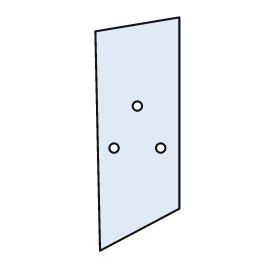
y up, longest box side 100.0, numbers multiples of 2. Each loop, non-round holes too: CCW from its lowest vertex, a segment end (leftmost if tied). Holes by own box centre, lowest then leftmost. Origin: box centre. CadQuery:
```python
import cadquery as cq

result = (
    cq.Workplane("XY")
    .moveTo(-16.0, -50.0)
    .lineTo(18.0, -32.0)
    .lineTo(18.0, 50.0)
    .lineTo(-18.0, 44.0)
    .close()
    .moveTo(-10.0, -6.0)
    .circle(2.0)
    .moveTo(10.0, -6.0)
    .circle(2.0)
    .moveTo(0.0, 12.0)
    .circle(2.0)
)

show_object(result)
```